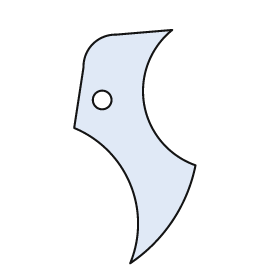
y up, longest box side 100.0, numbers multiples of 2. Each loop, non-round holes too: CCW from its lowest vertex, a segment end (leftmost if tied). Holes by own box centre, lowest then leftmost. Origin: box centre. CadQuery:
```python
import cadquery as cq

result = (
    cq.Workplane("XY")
    .moveTo(-2.0, -50.0)
    .threePointArc((16.0, -32.0), (26.0, -8.0))
    .threePointArc((4.0, 18.0), (16.0, 50.0))
    .lineTo(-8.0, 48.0)
    .threePointArc((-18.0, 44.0), (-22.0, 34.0))
    .lineTo(-26.0, 8.0)
    .threePointArc((-2.0, -16.0), (-2.0, -50.0))
    .close()
    .moveTo(-14.0, 20.0)
    .circle(4.0)
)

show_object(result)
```